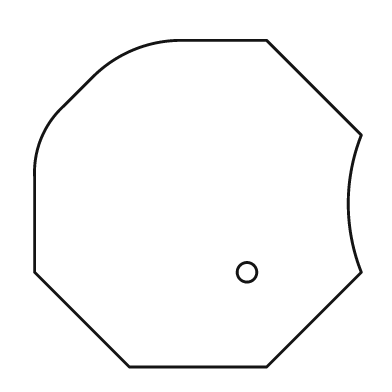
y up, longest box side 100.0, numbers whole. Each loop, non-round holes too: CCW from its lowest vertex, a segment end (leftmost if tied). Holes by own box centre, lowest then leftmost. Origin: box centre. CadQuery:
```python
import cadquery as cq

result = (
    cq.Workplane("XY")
    .moveTo(-21.0, -50.0)
    .lineTo(21.0, -50.0)
    .lineTo(50.0, -21.0)
    .threePointArc((46.0, 0.0), (50.0, 21.0))
    .lineTo(21.0, 50.0)
    .lineTo(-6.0, 50.0)
    .threePointArc((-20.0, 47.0), (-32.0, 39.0))
    .lineTo(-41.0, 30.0)
    .threePointArc((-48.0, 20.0), (-50.0, 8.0))
    .lineTo(-50.0, -21.0)
    .close()
    .moveTo(15.0, -21.0)
    .circle(3.0)
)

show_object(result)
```